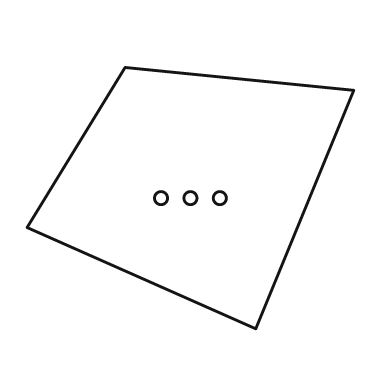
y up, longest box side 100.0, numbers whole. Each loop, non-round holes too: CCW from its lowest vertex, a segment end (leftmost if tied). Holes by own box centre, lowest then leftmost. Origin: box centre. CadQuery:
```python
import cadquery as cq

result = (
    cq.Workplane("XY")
    .moveTo(20.0, -40.0)
    .lineTo(50.0, 33.0)
    .lineTo(-20.0, 40.0)
    .lineTo(-50.0, -9.0)
    .close()
    .moveTo(-9.0, 0.0)
    .circle(2.0)
    .moveTo(0.0, 0.0)
    .circle(2.0)
    .moveTo(9.0, 0.0)
    .circle(2.0)
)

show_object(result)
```